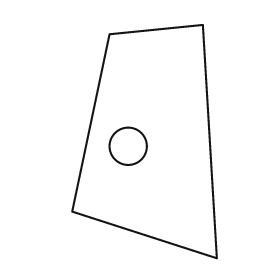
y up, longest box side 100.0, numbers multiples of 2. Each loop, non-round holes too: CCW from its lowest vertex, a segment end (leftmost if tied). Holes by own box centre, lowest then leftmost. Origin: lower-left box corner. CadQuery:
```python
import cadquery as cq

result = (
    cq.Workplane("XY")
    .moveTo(62.0, 0.0)
    .lineTo(56.0, 100.0)
    .lineTo(16.0, 96.0)
    .lineTo(0.0, 20.0)
    .close()
    .moveTo(24.0, 48.0)
    .circle(8.0)
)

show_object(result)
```